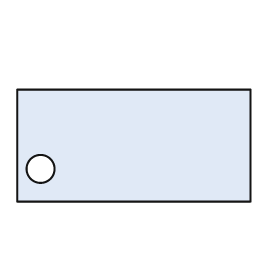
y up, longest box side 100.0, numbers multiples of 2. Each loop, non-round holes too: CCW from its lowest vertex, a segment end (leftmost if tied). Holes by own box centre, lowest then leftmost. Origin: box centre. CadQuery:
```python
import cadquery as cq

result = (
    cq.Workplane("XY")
    .moveTo(-50.0, -24.0)
    .lineTo(50.0, -24.0)
    .lineTo(50.0, 24.0)
    .lineTo(-50.0, 24.0)
    .close()
    .moveTo(-40.0, -10.0)
    .circle(6.0)
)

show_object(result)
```